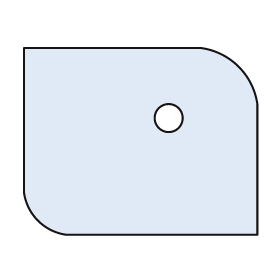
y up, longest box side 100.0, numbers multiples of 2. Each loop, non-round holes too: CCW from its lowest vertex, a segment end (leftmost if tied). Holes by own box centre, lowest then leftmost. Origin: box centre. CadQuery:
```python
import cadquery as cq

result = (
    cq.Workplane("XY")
    .moveTo(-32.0, -40.0)
    .lineTo(50.0, -40.0)
    .lineTo(50.0, 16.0)
    .threePointArc((42.0, 32.0), (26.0, 40.0))
    .lineTo(-50.0, 40.0)
    .lineTo(-50.0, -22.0)
    .threePointArc((-44.0, -34.0), (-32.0, -40.0))
    .close()
    .moveTo(12.0, 10.0)
    .circle(6.0)
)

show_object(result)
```